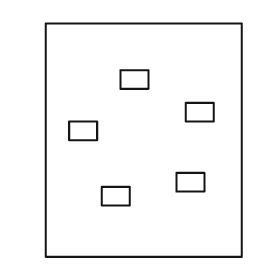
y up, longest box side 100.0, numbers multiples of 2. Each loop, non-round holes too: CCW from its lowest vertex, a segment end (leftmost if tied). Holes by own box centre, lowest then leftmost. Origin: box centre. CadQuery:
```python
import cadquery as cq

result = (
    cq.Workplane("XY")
    .moveTo(-42.0, -50.0)
    .lineTo(42.0, -50.0)
    .lineTo(42.0, 50.0)
    .lineTo(-42.0, 50.0)
    .close()
    .moveTo(-18.0, -28.0)
    .lineTo(-6.0, -28.0)
    .lineTo(-6.0, -20.0)
    .lineTo(-18.0, -20.0)
    .close()
    .moveTo(14.0, -22.0)
    .lineTo(26.0, -22.0)
    .lineTo(26.0, -14.0)
    .lineTo(14.0, -14.0)
    .close()
    .moveTo(-32.0, 0.0)
    .lineTo(-20.0, 0.0)
    .lineTo(-20.0, 8.0)
    .lineTo(-32.0, 8.0)
    .close()
    .moveTo(18.0, 8.0)
    .lineTo(30.0, 8.0)
    .lineTo(30.0, 16.0)
    .lineTo(18.0, 16.0)
    .close()
    .moveTo(-10.0, 22.0)
    .lineTo(2.0, 22.0)
    .lineTo(2.0, 30.0)
    .lineTo(-10.0, 30.0)
    .close()
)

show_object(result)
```